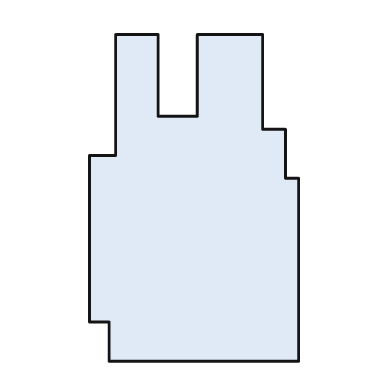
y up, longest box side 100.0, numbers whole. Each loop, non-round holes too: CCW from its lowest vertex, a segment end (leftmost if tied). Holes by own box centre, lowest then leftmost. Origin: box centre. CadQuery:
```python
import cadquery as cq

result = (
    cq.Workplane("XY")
    .moveTo(-26.0, -50.0)
    .lineTo(32.0, -50.0)
    .lineTo(32.0, 6.0)
    .lineTo(28.0, 6.0)
    .lineTo(28.0, 21.0)
    .lineTo(21.0, 21.0)
    .lineTo(21.0, 50.0)
    .lineTo(1.0, 50.0)
    .lineTo(1.0, 25.0)
    .lineTo(-11.0, 25.0)
    .lineTo(-11.0, 50.0)
    .lineTo(-24.0, 50.0)
    .lineTo(-24.0, 13.0)
    .lineTo(-32.0, 13.0)
    .lineTo(-32.0, -38.0)
    .lineTo(-26.0, -38.0)
    .close()
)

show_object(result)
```